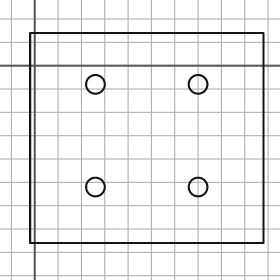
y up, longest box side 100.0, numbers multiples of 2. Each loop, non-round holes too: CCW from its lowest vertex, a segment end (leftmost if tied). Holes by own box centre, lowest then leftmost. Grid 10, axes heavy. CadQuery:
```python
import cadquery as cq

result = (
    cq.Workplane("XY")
    .moveTo(-2.0, -76.0)
    .lineTo(98.0, -76.0)
    .lineTo(98.0, 14.0)
    .lineTo(-2.0, 14.0)
    .close()
    .moveTo(26.0, -52.0)
    .circle(4.0)
    .moveTo(70.0, -52.0)
    .circle(4.0)
    .moveTo(26.0, -8.0)
    .circle(4.0)
    .moveTo(70.0, -8.0)
    .circle(4.0)
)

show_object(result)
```